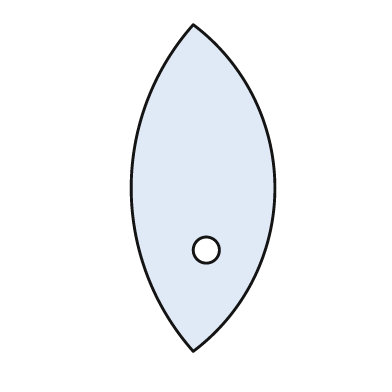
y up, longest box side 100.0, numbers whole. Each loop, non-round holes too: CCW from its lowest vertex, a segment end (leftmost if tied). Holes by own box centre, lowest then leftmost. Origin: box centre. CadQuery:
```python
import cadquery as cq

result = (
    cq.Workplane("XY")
    .moveTo(-3.0, -50.0)
    .threePointArc((22.0, 0.0), (-3.0, 50.0))
    .threePointArc((-22.0, 0.0), (-3.0, -50.0))
    .close()
    .moveTo(1.0, -19.0)
    .circle(4.0)
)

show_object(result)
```